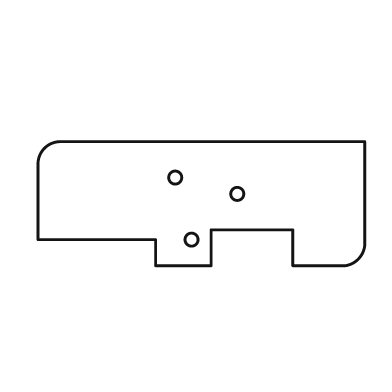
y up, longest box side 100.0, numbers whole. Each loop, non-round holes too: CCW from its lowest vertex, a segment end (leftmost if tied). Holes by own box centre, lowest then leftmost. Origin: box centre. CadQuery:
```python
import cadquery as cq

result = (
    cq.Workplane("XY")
    .moveTo(-14.0, -19.0)
    .lineTo(3.0, -19.0)
    .lineTo(3.0, -8.0)
    .lineTo(28.0, -8.0)
    .lineTo(28.0, -19.0)
    .lineTo(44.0, -19.0)
    .threePointArc((48.0, -17.0), (50.0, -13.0))
    .lineTo(50.0, 19.0)
    .lineTo(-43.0, 19.0)
    .threePointArc((-48.0, 17.0), (-50.0, 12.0))
    .lineTo(-50.0, -11.0)
    .lineTo(-14.0, -11.0)
    .close()
    .moveTo(-3.0, -11.0)
    .circle(2.0)
    .moveTo(11.0, 3.0)
    .circle(2.0)
    .moveTo(-8.0, 8.0)
    .circle(2.0)
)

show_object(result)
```